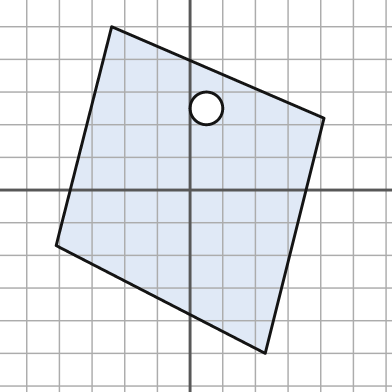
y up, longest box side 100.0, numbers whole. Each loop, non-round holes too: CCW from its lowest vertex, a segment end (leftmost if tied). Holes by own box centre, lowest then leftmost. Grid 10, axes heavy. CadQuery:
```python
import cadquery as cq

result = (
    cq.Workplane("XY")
    .moveTo(23.0, -50.0)
    .lineTo(41.0, 22.0)
    .lineTo(-24.0, 50.0)
    .lineTo(-41.0, -17.0)
    .close()
    .moveTo(5.0, 25.0)
    .circle(5.0)
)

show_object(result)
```